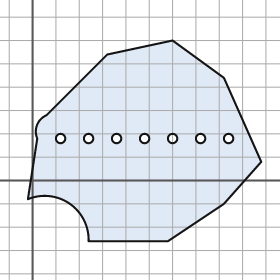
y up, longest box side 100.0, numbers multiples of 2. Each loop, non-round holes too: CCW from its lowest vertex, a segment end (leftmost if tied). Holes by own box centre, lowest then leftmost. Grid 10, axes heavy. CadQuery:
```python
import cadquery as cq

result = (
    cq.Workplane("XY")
    .moveTo(24.0, -26.0)
    .lineTo(58.0, -26.0)
    .lineTo(82.0, -10.0)
    .lineTo(98.0, 8.0)
    .lineTo(82.0, 44.0)
    .lineTo(60.0, 60.0)
    .lineTo(32.0, 54.0)
    .lineTo(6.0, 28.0)
    .threePointArc((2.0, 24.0), (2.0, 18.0))
    .lineTo(-2.0, -8.0)
    .threePointArc((16.0, -10.0), (24.0, -26.0))
    .close()
    .moveTo(12.0, 18.0)
    .circle(2.0)
    .moveTo(24.0, 18.0)
    .circle(2.0)
    .moveTo(36.0, 18.0)
    .circle(2.0)
    .moveTo(48.0, 18.0)
    .circle(2.0)
    .moveTo(60.0, 18.0)
    .circle(2.0)
    .moveTo(72.0, 18.0)
    .circle(2.0)
    .moveTo(84.0, 18.0)
    .circle(2.0)
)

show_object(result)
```